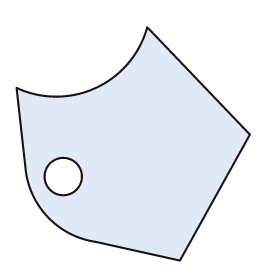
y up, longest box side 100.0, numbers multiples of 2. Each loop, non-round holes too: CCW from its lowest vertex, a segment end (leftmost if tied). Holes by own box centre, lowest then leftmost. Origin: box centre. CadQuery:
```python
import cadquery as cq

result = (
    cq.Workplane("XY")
    .moveTo(20.0, -50.0)
    .lineTo(50.0, 4.0)
    .lineTo(6.0, 50.0)
    .threePointArc((-16.0, 24.0), (-50.0, 24.0))
    .lineTo(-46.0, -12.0)
    .threePointArc((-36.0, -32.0), (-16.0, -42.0))
    .close()
    .moveTo(-30.0, -14.0)
    .circle(8.0)
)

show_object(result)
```